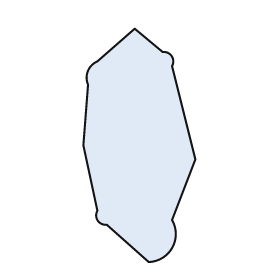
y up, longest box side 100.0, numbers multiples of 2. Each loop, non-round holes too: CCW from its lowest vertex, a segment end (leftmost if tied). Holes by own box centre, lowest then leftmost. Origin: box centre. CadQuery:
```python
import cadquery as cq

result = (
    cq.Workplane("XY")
    .moveTo(4.0, -50.0)
    .threePointArc((14.0, -44.0), (14.0, -32.0))
    .lineTo(24.0, -6.0)
    .lineTo(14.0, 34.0)
    .threePointArc((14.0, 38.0), (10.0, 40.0))
    .lineTo(-2.0, 50.0)
    .lineTo(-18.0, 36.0)
    .threePointArc((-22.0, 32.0), (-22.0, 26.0))
    .lineTo(-24.0, 0.0)
    .lineTo(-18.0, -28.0)
    .threePointArc((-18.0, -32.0), (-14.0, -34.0))
    .close()
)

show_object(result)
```